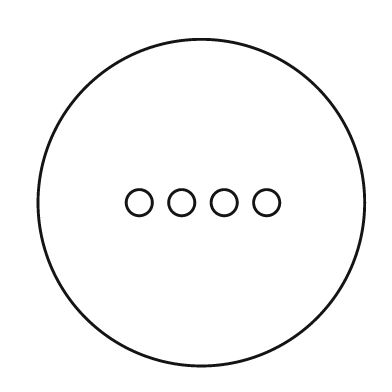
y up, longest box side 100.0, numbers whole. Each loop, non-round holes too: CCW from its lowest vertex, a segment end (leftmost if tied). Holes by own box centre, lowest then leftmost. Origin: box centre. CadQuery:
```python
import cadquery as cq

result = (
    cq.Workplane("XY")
    .moveTo(0.0, 0.0)
    .circle(50.0)
    .moveTo(-19.0, 0.0)
    .circle(4.0)
    .moveTo(-6.0, 0.0)
    .circle(4.0)
    .moveTo(7.0, 0.0)
    .circle(4.0)
    .moveTo(20.0, 0.0)
    .circle(4.0)
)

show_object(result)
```